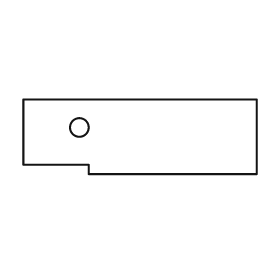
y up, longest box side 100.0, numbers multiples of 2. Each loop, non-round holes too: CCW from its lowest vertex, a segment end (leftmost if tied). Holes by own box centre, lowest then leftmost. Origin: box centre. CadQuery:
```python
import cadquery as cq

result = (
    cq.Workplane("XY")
    .moveTo(-22.0, -16.0)
    .lineTo(50.0, -16.0)
    .lineTo(50.0, 16.0)
    .lineTo(-50.0, 16.0)
    .lineTo(-50.0, -12.0)
    .lineTo(-22.0, -12.0)
    .close()
    .moveTo(-26.0, 4.0)
    .circle(4.0)
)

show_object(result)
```